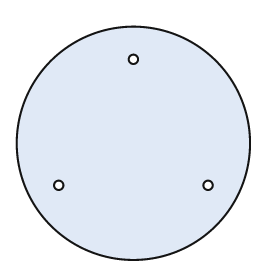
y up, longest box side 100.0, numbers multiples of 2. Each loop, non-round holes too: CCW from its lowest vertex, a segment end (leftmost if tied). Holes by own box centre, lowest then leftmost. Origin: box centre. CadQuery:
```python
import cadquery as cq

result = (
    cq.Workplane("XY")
    .moveTo(0.0, 0.0)
    .circle(50.0)
    .moveTo(-32.0, -18.0)
    .circle(2.0)
    .moveTo(32.0, -18.0)
    .circle(2.0)
    .moveTo(0.0, 36.0)
    .circle(2.0)
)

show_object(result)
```